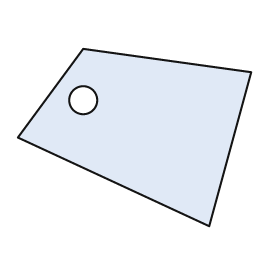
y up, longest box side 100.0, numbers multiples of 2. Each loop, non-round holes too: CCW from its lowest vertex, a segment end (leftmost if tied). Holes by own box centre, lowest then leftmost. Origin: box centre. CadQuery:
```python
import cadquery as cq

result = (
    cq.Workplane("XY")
    .moveTo(32.0, -38.0)
    .lineTo(50.0, 28.0)
    .lineTo(-22.0, 38.0)
    .lineTo(-50.0, 0.0)
    .close()
    .moveTo(-22.0, 16.0)
    .circle(6.0)
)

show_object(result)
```